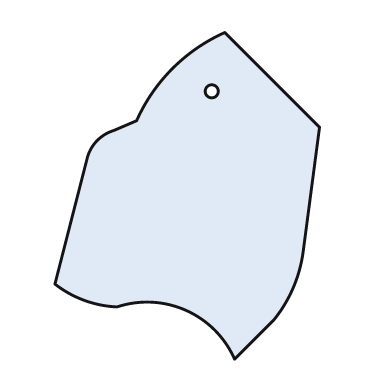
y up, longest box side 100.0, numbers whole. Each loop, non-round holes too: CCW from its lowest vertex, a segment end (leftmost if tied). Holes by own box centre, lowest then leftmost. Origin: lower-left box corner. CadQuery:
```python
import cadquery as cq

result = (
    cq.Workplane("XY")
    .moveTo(55.0, 0.0)
    .lineTo(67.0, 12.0)
    .threePointArc((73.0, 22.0), (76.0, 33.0))
    .lineTo(81.0, 71.0)
    .lineTo(52.0, 100.0)
    .threePointArc((36.0, 89.0), (25.0, 73.0))
    .lineTo(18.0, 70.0)
    .threePointArc((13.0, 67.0), (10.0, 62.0))
    .lineTo(0.0, 23.0)
    .threePointArc((9.0, 18.0), (19.0, 16.0))
    .threePointArc((40.0, 15.0), (55.0, 0.0))
    .close()
    .moveTo(48.0, 82.0)
    .circle(2.0)
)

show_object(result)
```